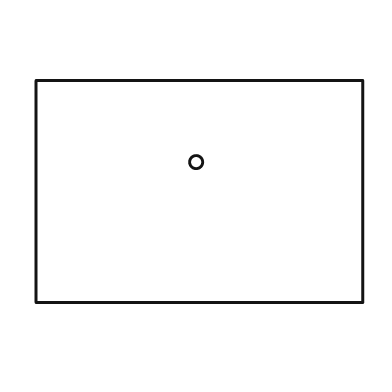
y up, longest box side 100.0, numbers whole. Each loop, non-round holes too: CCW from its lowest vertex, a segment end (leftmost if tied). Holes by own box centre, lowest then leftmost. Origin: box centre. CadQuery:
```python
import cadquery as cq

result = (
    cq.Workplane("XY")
    .moveTo(-50.0, -34.0)
    .lineTo(50.0, -34.0)
    .lineTo(50.0, 34.0)
    .lineTo(-50.0, 34.0)
    .close()
    .moveTo(-1.0, 9.0)
    .circle(2.0)
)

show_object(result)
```